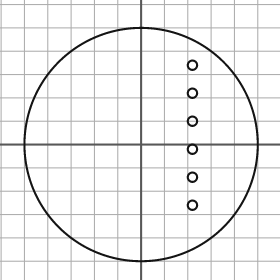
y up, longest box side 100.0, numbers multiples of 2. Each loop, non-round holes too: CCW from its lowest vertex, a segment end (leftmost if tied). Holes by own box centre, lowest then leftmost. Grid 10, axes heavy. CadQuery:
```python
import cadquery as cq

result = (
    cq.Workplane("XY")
    .moveTo(0.0, 0.0)
    .circle(50.0)
    .moveTo(22.0, -26.0)
    .circle(2.0)
    .moveTo(22.0, -14.0)
    .circle(2.0)
    .moveTo(22.0, -2.0)
    .circle(2.0)
    .moveTo(22.0, 10.0)
    .circle(2.0)
    .moveTo(22.0, 22.0)
    .circle(2.0)
    .moveTo(22.0, 34.0)
    .circle(2.0)
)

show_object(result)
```